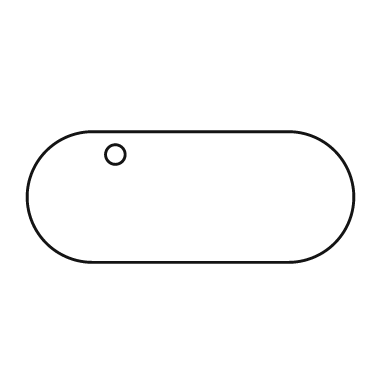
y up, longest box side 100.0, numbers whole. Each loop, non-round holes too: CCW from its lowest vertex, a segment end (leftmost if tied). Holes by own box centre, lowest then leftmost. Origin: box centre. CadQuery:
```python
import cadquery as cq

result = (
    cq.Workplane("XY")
    .moveTo(-30.0, -20.0)
    .lineTo(30.0, -20.0)
    .threePointArc((50.0, 0.0), (30.0, 20.0))
    .lineTo(-30.0, 20.0)
    .threePointArc((-50.0, 0.0), (-30.0, -20.0))
    .close()
    .moveTo(-23.0, 13.0)
    .circle(3.0)
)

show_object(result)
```